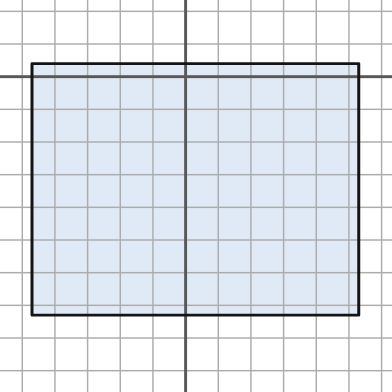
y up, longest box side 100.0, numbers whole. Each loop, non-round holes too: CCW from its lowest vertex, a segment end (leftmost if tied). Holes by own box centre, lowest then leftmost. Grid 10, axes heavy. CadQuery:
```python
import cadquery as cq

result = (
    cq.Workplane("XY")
    .moveTo(-47.0, -73.0)
    .lineTo(53.0, -73.0)
    .lineTo(53.0, 4.0)
    .lineTo(-47.0, 4.0)
    .close()
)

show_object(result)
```